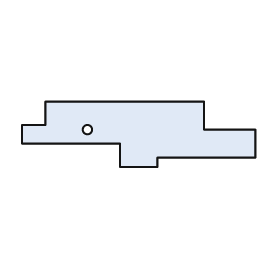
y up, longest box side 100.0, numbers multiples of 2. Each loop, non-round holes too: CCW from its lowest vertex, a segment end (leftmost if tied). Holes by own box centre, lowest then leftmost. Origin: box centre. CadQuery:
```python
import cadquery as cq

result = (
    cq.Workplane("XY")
    .moveTo(-8.0, -14.0)
    .lineTo(8.0, -14.0)
    .lineTo(8.0, -10.0)
    .lineTo(50.0, -10.0)
    .lineTo(50.0, 2.0)
    .lineTo(28.0, 2.0)
    .lineTo(28.0, 14.0)
    .lineTo(-40.0, 14.0)
    .lineTo(-40.0, 4.0)
    .lineTo(-50.0, 4.0)
    .lineTo(-50.0, -4.0)
    .lineTo(-8.0, -4.0)
    .close()
    .moveTo(-22.0, 2.0)
    .circle(2.0)
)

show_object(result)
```